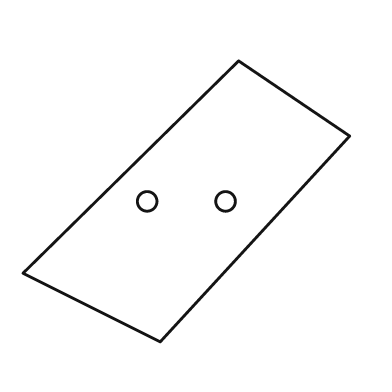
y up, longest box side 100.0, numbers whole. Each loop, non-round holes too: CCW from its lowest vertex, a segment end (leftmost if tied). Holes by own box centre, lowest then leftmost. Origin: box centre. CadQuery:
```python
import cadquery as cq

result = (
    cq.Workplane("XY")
    .moveTo(-8.0, -43.0)
    .lineTo(50.0, 20.0)
    .lineTo(16.0, 43.0)
    .lineTo(-50.0, -22.0)
    .close()
    .moveTo(-12.0, 0.0)
    .circle(3.0)
    .moveTo(12.0, 0.0)
    .circle(3.0)
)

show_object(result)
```